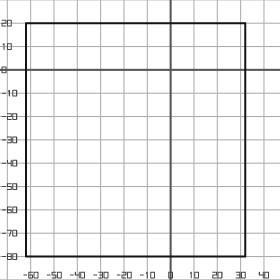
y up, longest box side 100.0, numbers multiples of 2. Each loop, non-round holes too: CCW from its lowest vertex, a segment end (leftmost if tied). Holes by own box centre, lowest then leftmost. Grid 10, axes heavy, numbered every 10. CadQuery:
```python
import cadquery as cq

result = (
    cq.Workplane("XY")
    .moveTo(-62.0, -80.0)
    .lineTo(32.0, -80.0)
    .lineTo(32.0, 20.0)
    .lineTo(-62.0, 20.0)
    .close()
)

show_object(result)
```